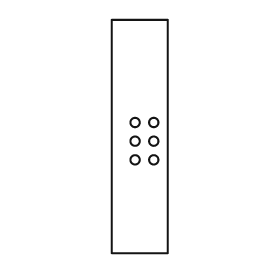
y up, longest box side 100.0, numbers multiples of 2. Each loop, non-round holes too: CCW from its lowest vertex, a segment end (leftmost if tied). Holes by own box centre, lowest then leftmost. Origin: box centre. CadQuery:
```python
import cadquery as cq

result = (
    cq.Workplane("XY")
    .moveTo(-12.0, -50.0)
    .lineTo(12.0, -50.0)
    .lineTo(12.0, 50.0)
    .lineTo(-12.0, 50.0)
    .close()
    .moveTo(-2.0, -10.0)
    .circle(2.0)
    .moveTo(6.0, -10.0)
    .circle(2.0)
    .moveTo(-2.0, -2.0)
    .circle(2.0)
    .moveTo(6.0, -2.0)
    .circle(2.0)
    .moveTo(-2.0, 6.0)
    .circle(2.0)
    .moveTo(6.0, 6.0)
    .circle(2.0)
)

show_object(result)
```